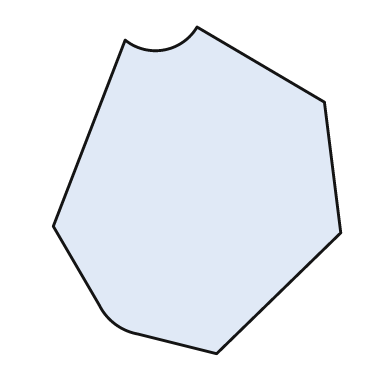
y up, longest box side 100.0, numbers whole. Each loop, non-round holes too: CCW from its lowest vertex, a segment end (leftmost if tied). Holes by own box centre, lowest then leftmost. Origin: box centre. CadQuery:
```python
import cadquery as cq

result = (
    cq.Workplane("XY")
    .moveTo(6.0, -50.0)
    .lineTo(44.0, -13.0)
    .lineTo(39.0, 27.0)
    .lineTo(0.0, 50.0)
    .threePointArc((-10.0, 43.0), (-22.0, 46.0))
    .lineTo(-44.0, -11.0)
    .lineTo(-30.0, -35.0)
    .threePointArc((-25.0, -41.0), (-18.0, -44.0))
    .close()
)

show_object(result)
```